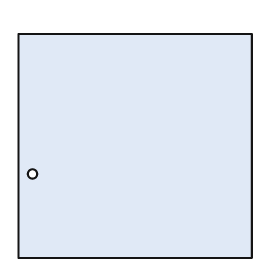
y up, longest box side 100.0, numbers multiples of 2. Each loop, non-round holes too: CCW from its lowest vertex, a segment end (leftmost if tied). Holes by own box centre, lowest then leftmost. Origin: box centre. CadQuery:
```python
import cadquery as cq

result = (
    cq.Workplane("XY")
    .moveTo(-50.0, -48.0)
    .lineTo(50.0, -48.0)
    .lineTo(50.0, 48.0)
    .lineTo(-50.0, 48.0)
    .close()
    .moveTo(-44.0, -12.0)
    .circle(2.0)
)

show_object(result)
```